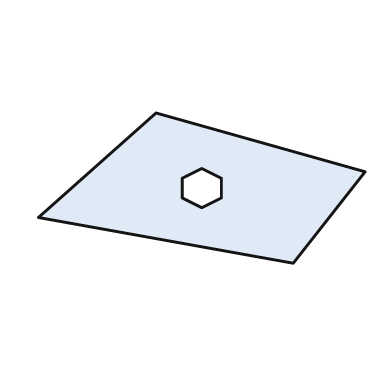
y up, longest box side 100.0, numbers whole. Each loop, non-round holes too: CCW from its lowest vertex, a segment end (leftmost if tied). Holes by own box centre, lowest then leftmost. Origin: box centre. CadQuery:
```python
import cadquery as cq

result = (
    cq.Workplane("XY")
    .moveTo(28.0, -23.0)
    .lineTo(50.0, 5.0)
    .lineTo(-14.0, 23.0)
    .lineTo(-50.0, -9.0)
    .close()
    .moveTo(0.0, -6.0)
    .lineTo(6.0, -3.0)
    .lineTo(6.0, 3.0)
    .lineTo(0.0, 6.0)
    .lineTo(-6.0, 3.0)
    .lineTo(-6.0, -3.0)
    .close()
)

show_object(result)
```